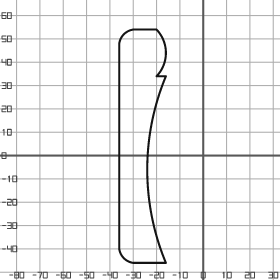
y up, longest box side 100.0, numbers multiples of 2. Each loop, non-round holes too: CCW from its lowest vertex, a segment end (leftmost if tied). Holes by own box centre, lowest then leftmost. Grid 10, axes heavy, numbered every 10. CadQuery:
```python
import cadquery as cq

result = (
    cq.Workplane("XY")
    .moveTo(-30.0, -46.0)
    .lineTo(-16.0, -46.0)
    .threePointArc((-24.0, -6.0), (-16.0, 34.0))
    .lineTo(-20.0, 34.0)
    .threePointArc((-16.0, 44.0), (-20.0, 54.0))
    .lineTo(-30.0, 54.0)
    .threePointArc((-34.0, 52.0), (-36.0, 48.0))
    .lineTo(-36.0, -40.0)
    .threePointArc((-34.0, -44.0), (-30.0, -46.0))
    .close()
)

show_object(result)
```